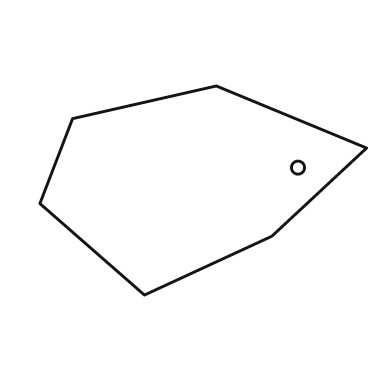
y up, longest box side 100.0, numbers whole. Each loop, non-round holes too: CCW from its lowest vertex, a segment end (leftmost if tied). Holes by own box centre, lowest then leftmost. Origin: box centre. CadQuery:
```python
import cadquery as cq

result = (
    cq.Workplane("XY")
    .moveTo(-18.0, -32.0)
    .lineTo(21.0, -14.0)
    .lineTo(50.0, 13.0)
    .lineTo(4.0, 32.0)
    .lineTo(-40.0, 22.0)
    .lineTo(-50.0, -4.0)
    .close()
    .moveTo(29.0, 7.0)
    .circle(2.0)
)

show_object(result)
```